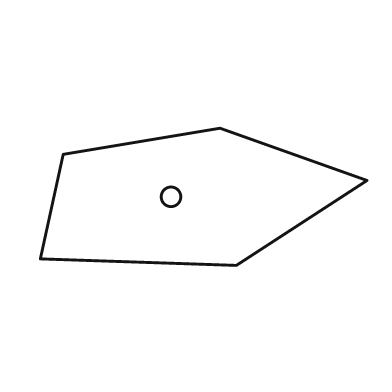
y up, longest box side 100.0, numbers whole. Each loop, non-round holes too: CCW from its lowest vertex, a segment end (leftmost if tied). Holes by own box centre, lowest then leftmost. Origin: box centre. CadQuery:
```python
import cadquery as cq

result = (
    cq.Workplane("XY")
    .moveTo(10.0, -21.0)
    .lineTo(50.0, 5.0)
    .lineTo(5.0, 21.0)
    .lineTo(-43.0, 13.0)
    .lineTo(-50.0, -19.0)
    .close()
    .moveTo(-10.0, 0.0)
    .circle(3.0)
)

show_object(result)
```